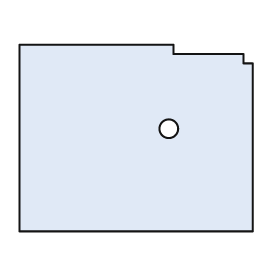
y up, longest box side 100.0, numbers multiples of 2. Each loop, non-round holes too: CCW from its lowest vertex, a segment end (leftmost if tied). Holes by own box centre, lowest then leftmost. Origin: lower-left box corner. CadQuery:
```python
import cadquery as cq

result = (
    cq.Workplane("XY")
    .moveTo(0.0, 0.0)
    .lineTo(100.0, 0.0)
    .lineTo(100.0, 72.0)
    .lineTo(96.0, 72.0)
    .lineTo(96.0, 76.0)
    .lineTo(66.0, 76.0)
    .lineTo(66.0, 80.0)
    .lineTo(0.0, 80.0)
    .close()
    .moveTo(64.0, 44.0)
    .circle(4.0)
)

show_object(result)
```